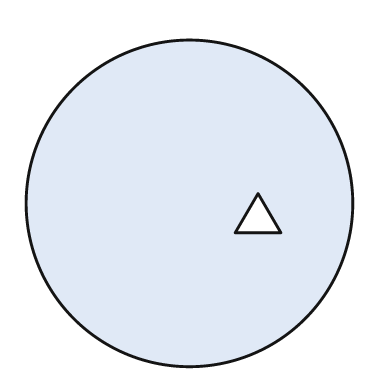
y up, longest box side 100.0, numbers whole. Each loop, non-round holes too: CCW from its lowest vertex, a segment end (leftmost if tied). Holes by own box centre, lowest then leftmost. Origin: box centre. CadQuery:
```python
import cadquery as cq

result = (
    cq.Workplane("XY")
    .moveTo(0.0, 0.0)
    .circle(50.0)
    .moveTo(14.0, -9.0)
    .lineTo(28.0, -9.0)
    .lineTo(21.0, 3.0)
    .close()
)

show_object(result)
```